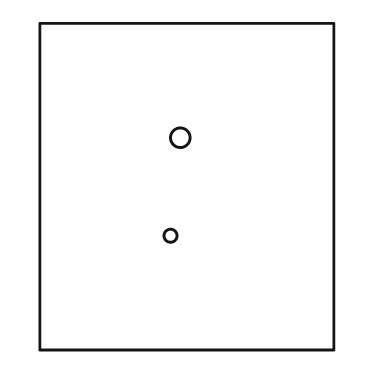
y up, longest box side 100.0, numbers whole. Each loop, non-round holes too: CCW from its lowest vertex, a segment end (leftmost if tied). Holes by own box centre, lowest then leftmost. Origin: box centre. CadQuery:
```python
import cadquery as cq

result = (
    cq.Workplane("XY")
    .moveTo(-45.0, -50.0)
    .lineTo(45.0, -50.0)
    .lineTo(45.0, 50.0)
    .lineTo(-45.0, 50.0)
    .close()
    .moveTo(-5.0, -15.0)
    .circle(2.0)
    .moveTo(-2.0, 15.0)
    .circle(3.0)
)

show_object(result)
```